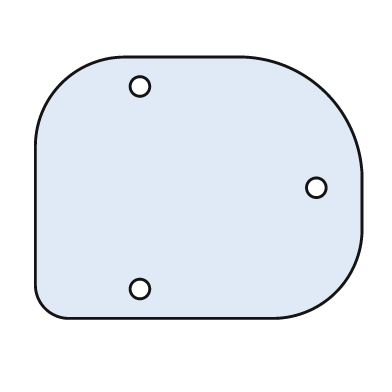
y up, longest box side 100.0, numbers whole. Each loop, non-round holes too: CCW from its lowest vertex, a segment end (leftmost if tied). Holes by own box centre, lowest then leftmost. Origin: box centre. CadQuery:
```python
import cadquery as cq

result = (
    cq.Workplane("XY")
    .moveTo(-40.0, -40.0)
    .lineTo(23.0, -40.0)
    .threePointArc((42.0, -32.0), (50.0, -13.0))
    .lineTo(50.0, 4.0)
    .threePointArc((39.0, 29.0), (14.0, 40.0))
    .lineTo(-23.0, 40.0)
    .threePointArc((-42.0, 32.0), (-50.0, 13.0))
    .lineTo(-50.0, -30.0)
    .threePointArc((-47.0, -37.0), (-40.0, -40.0))
    .close()
    .moveTo(-18.0, -31.0)
    .circle(3.0)
    .moveTo(36.0, 0.0)
    .circle(3.0)
    .moveTo(-18.0, 31.0)
    .circle(3.0)
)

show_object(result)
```